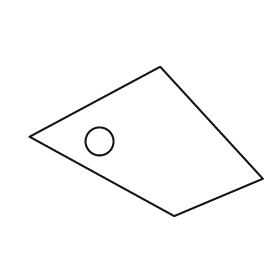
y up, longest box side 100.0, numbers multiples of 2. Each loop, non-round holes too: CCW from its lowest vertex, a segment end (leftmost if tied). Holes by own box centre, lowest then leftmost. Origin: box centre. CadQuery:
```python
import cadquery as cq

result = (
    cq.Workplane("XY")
    .moveTo(12.0, -32.0)
    .lineTo(50.0, -16.0)
    .lineTo(6.0, 32.0)
    .lineTo(-50.0, 2.0)
    .close()
    .moveTo(-20.0, 0.0)
    .circle(6.0)
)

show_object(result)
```